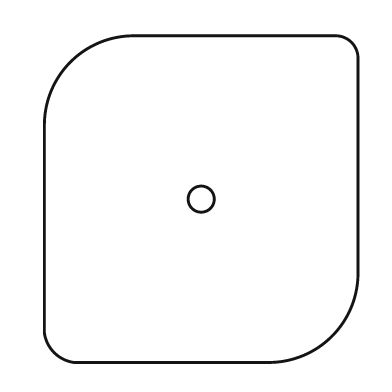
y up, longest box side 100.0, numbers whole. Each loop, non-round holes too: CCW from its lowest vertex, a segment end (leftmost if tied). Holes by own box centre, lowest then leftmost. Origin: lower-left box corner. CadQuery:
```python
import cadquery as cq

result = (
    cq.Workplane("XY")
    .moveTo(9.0, 0.0)
    .lineTo(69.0, 0.0)
    .threePointArc((88.0, 8.0), (96.0, 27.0))
    .lineTo(96.0, 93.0)
    .threePointArc((94.0, 98.0), (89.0, 100.0))
    .lineTo(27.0, 100.0)
    .threePointArc((8.0, 92.0), (0.0, 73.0))
    .lineTo(0.0, 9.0)
    .threePointArc((3.0, 3.0), (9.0, 0.0))
    .close()
    .moveTo(48.0, 50.0)
    .circle(4.0)
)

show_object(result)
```